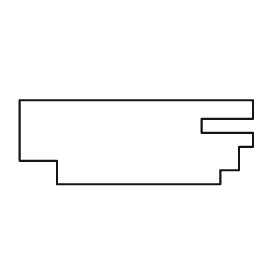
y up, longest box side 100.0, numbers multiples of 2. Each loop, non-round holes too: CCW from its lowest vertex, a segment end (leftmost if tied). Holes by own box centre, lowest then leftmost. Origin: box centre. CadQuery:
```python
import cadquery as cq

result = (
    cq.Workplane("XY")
    .moveTo(-34.0, -18.0)
    .lineTo(36.0, -18.0)
    .lineTo(36.0, -12.0)
    .lineTo(44.0, -12.0)
    .lineTo(44.0, -2.0)
    .lineTo(50.0, -2.0)
    .lineTo(50.0, 4.0)
    .lineTo(28.0, 4.0)
    .lineTo(28.0, 10.0)
    .lineTo(50.0, 10.0)
    .lineTo(50.0, 18.0)
    .lineTo(-50.0, 18.0)
    .lineTo(-50.0, -8.0)
    .lineTo(-34.0, -8.0)
    .close()
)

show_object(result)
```